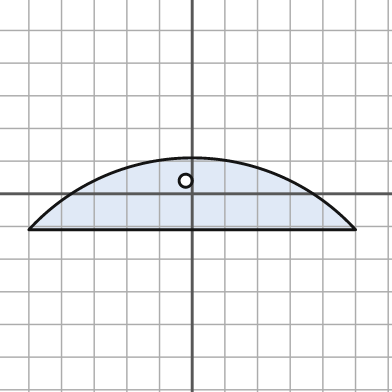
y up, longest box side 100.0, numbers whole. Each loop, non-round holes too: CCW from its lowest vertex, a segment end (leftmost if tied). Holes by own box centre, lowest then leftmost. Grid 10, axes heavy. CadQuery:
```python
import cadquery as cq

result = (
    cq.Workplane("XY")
    .moveTo(-50.0, -11.0)
    .lineTo(50.0, -11.0)
    .threePointArc((0.0, 11.0), (-50.0, -11.0))
    .close()
    .moveTo(-2.0, 4.0)
    .circle(2.0)
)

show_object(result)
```